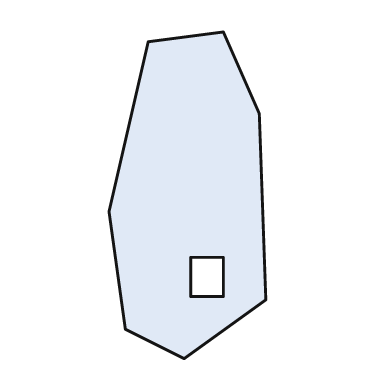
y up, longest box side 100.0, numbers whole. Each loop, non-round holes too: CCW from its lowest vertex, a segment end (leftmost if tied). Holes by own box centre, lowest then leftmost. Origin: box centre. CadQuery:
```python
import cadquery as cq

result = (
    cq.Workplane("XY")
    .moveTo(-1.0, -50.0)
    .lineTo(24.0, -32.0)
    .lineTo(22.0, 25.0)
    .lineTo(11.0, 50.0)
    .lineTo(-12.0, 47.0)
    .lineTo(-24.0, -5.0)
    .lineTo(-19.0, -41.0)
    .close()
    .moveTo(1.0, -31.0)
    .lineTo(11.0, -31.0)
    .lineTo(11.0, -19.0)
    .lineTo(1.0, -19.0)
    .close()
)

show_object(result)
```